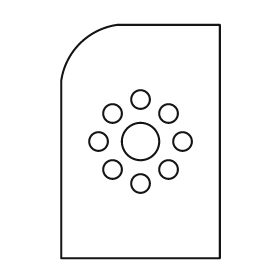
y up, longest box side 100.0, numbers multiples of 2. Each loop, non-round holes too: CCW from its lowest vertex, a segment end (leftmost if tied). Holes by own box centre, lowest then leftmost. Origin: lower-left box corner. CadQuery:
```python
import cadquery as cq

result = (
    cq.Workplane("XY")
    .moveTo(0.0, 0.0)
    .lineTo(68.0, 0.0)
    .lineTo(68.0, 100.0)
    .lineTo(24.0, 100.0)
    .threePointArc((8.0, 92.0), (0.0, 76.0))
    .close()
    .moveTo(34.0, 32.0)
    .circle(4.0)
    .moveTo(22.0, 38.0)
    .circle(4.0)
    .moveTo(46.0, 38.0)
    .circle(4.0)
    .moveTo(16.0, 50.0)
    .circle(4.0)
    .moveTo(34.0, 50.0)
    .circle(8.0)
    .moveTo(52.0, 50.0)
    .circle(4.0)
    .moveTo(22.0, 62.0)
    .circle(4.0)
    .moveTo(46.0, 62.0)
    .circle(4.0)
    .moveTo(34.0, 68.0)
    .circle(4.0)
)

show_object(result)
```